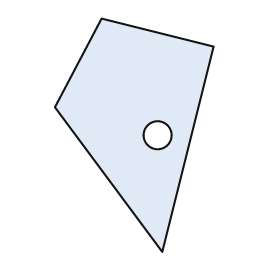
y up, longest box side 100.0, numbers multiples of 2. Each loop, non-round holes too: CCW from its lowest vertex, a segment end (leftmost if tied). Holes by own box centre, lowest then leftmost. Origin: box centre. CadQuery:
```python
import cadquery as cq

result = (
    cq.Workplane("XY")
    .moveTo(12.0, -50.0)
    .lineTo(34.0, 38.0)
    .lineTo(-14.0, 50.0)
    .lineTo(-34.0, 12.0)
    .close()
    .moveTo(10.0, 0.0)
    .circle(6.0)
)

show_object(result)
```